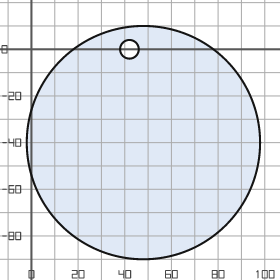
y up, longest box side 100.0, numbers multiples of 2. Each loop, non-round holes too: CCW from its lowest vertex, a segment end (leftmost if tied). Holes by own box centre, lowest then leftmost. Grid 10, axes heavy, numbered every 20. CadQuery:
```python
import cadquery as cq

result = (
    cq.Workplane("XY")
    .moveTo(48.0, -40.0)
    .circle(50.0)
    .moveTo(42.0, 0.0)
    .circle(4.0)
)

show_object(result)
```